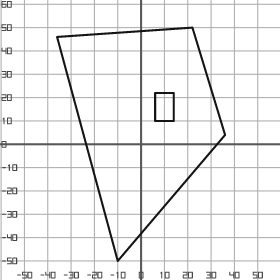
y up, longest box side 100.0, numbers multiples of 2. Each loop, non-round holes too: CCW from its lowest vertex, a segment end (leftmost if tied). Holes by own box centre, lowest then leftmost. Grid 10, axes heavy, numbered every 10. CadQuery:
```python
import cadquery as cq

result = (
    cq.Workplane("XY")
    .moveTo(-10.0, -50.0)
    .lineTo(36.0, 4.0)
    .lineTo(22.0, 50.0)
    .lineTo(-36.0, 46.0)
    .close()
    .moveTo(6.0, 10.0)
    .lineTo(14.0, 10.0)
    .lineTo(14.0, 22.0)
    .lineTo(6.0, 22.0)
    .close()
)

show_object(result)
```